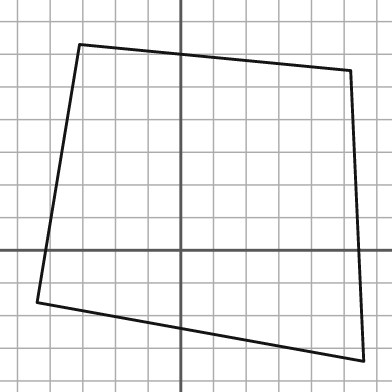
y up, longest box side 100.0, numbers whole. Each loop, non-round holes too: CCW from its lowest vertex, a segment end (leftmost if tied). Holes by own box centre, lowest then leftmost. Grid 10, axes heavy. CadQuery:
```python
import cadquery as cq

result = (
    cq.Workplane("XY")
    .moveTo(56.0, -34.0)
    .lineTo(52.0, 55.0)
    .lineTo(-31.0, 63.0)
    .lineTo(-44.0, -16.0)
    .close()
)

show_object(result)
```